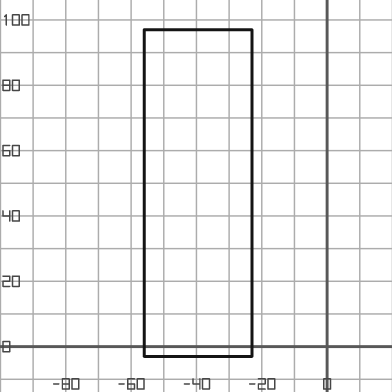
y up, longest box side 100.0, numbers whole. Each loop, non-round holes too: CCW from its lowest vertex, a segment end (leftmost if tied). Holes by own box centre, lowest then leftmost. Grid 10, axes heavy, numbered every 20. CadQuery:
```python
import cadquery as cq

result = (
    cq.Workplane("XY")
    .moveTo(-56.0, -3.0)
    .lineTo(-23.0, -3.0)
    .lineTo(-23.0, 97.0)
    .lineTo(-56.0, 97.0)
    .close()
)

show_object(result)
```